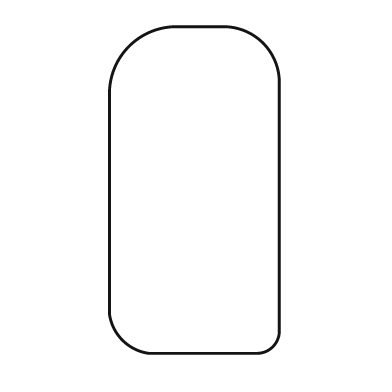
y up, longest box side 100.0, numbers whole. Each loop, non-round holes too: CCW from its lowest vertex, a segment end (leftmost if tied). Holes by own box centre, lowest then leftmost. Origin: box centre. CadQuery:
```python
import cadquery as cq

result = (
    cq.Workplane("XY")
    .moveTo(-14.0, -50.0)
    .lineTo(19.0, -50.0)
    .threePointArc((24.0, -48.0), (26.0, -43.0))
    .lineTo(26.0, 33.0)
    .threePointArc((21.0, 45.0), (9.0, 50.0))
    .lineTo(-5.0, 50.0)
    .threePointArc((-20.0, 44.0), (-26.0, 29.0))
    .lineTo(-26.0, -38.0)
    .threePointArc((-22.0, -46.0), (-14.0, -50.0))
    .close()
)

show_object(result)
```